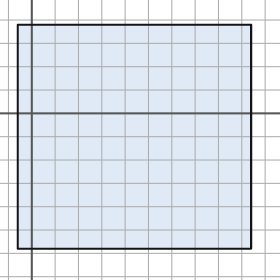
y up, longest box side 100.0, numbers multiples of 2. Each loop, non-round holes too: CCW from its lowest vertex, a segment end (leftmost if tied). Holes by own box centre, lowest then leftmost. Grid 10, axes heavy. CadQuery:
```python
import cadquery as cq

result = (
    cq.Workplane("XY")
    .moveTo(-6.0, -58.0)
    .lineTo(94.0, -58.0)
    .lineTo(94.0, 38.0)
    .lineTo(-6.0, 38.0)
    .close()
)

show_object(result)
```